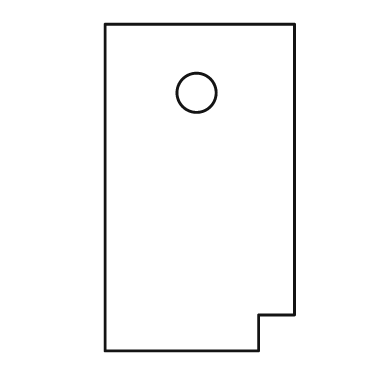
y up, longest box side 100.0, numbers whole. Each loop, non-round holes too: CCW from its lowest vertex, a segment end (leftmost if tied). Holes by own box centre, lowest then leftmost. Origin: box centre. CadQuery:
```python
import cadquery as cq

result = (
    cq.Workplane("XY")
    .moveTo(-29.0, -50.0)
    .lineTo(18.0, -50.0)
    .lineTo(18.0, -39.0)
    .lineTo(29.0, -39.0)
    .lineTo(29.0, 50.0)
    .lineTo(-29.0, 50.0)
    .close()
    .moveTo(-1.0, 29.0)
    .circle(6.0)
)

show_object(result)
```